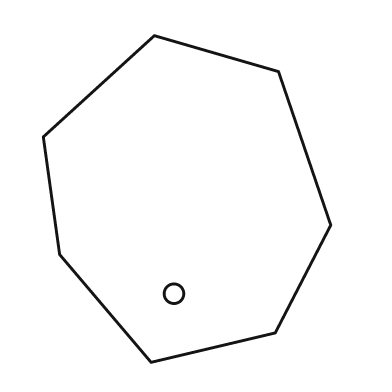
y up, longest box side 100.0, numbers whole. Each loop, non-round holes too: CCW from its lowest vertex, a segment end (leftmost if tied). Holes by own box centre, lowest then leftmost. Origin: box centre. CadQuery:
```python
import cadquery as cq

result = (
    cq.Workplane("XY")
    .moveTo(-11.0, -50.0)
    .lineTo(27.0, -41.0)
    .lineTo(44.0, -8.0)
    .lineTo(28.0, 39.0)
    .lineTo(-10.0, 50.0)
    .lineTo(-44.0, 19.0)
    .lineTo(-39.0, -17.0)
    .close()
    .moveTo(-4.0, -29.0)
    .circle(3.0)
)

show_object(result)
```